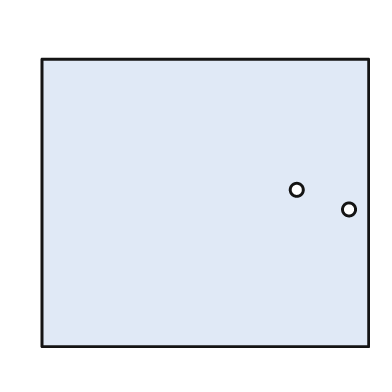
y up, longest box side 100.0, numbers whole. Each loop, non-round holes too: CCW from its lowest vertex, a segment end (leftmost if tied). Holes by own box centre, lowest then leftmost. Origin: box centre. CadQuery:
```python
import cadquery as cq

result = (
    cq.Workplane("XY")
    .moveTo(-50.0, -44.0)
    .lineTo(50.0, -44.0)
    .lineTo(50.0, 44.0)
    .lineTo(-50.0, 44.0)
    .close()
    .moveTo(44.0, -2.0)
    .circle(2.0)
    .moveTo(28.0, 4.0)
    .circle(2.0)
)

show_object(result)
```